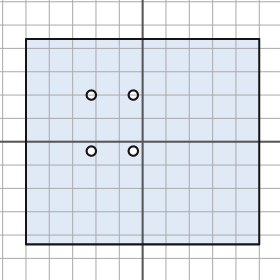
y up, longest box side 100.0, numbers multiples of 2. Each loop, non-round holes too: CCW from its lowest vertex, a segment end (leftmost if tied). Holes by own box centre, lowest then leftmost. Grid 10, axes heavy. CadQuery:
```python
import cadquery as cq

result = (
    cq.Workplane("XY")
    .moveTo(-50.0, -44.0)
    .lineTo(50.0, -44.0)
    .lineTo(50.0, 44.0)
    .lineTo(-50.0, 44.0)
    .close()
    .moveTo(-22.0, -4.0)
    .circle(2.0)
    .moveTo(-4.0, -4.0)
    .circle(2.0)
    .moveTo(-22.0, 20.0)
    .circle(2.0)
    .moveTo(-4.0, 20.0)
    .circle(2.0)
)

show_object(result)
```